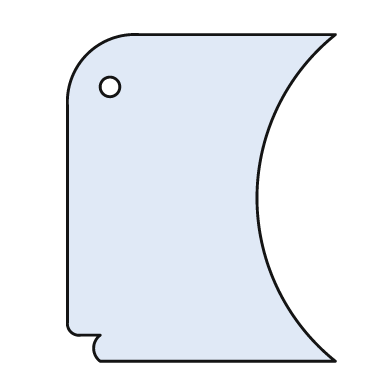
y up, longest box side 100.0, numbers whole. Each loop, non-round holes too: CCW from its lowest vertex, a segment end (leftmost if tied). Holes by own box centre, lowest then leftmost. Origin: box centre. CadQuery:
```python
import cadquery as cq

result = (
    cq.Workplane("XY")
    .moveTo(-31.0, -50.0)
    .lineTo(41.0, -50.0)
    .threePointArc((17.0, 0.0), (41.0, 50.0))
    .lineTo(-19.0, 50.0)
    .threePointArc((-35.0, 44.0), (-41.0, 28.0))
    .lineTo(-41.0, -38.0)
    .threePointArc((-40.0, -41.0), (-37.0, -42.0))
    .lineTo(-31.0, -42.0)
    .threePointArc((-33.0, -46.0), (-31.0, -50.0))
    .close()
    .moveTo(-28.0, 34.0)
    .circle(3.0)
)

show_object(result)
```